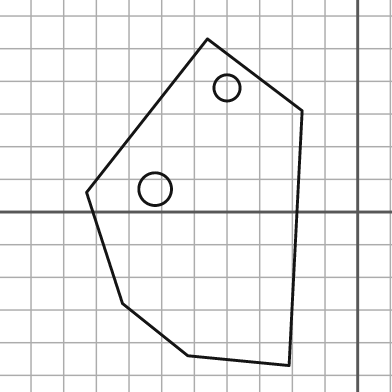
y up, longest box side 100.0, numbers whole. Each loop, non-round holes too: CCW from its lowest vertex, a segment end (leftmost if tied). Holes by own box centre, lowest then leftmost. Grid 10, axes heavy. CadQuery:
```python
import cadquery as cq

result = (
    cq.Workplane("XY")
    .moveTo(-21.0, -47.0)
    .lineTo(-17.0, 31.0)
    .lineTo(-46.0, 53.0)
    .lineTo(-83.0, 6.0)
    .lineTo(-72.0, -28.0)
    .lineTo(-52.0, -44.0)
    .close()
    .moveTo(-62.0, 7.0)
    .circle(5.0)
    .moveTo(-40.0, 38.0)
    .circle(4.0)
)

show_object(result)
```